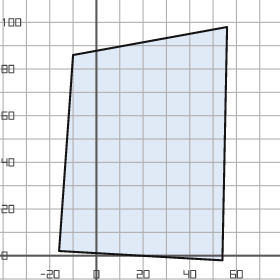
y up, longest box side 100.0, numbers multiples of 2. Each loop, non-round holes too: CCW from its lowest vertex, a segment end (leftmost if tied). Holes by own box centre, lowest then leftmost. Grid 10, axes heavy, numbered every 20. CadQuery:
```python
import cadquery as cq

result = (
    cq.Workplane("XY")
    .moveTo(54.0, -2.0)
    .lineTo(56.0, 98.0)
    .lineTo(-10.0, 86.0)
    .lineTo(-16.0, 2.0)
    .close()
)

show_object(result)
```